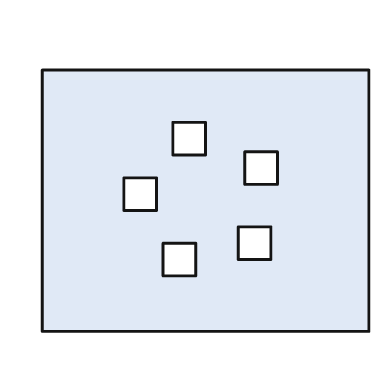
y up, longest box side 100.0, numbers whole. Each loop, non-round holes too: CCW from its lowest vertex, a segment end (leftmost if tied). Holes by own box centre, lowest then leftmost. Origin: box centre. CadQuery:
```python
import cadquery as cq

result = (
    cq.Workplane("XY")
    .moveTo(-50.0, -40.0)
    .lineTo(50.0, -40.0)
    .lineTo(50.0, 40.0)
    .lineTo(-50.0, 40.0)
    .close()
    .moveTo(-13.0, -23.0)
    .lineTo(-3.0, -23.0)
    .lineTo(-3.0, -13.0)
    .lineTo(-13.0, -13.0)
    .close()
    .moveTo(10.0, -18.0)
    .lineTo(20.0, -18.0)
    .lineTo(20.0, -8.0)
    .lineTo(10.0, -8.0)
    .close()
    .moveTo(-25.0, -3.0)
    .lineTo(-15.0, -3.0)
    .lineTo(-15.0, 7.0)
    .lineTo(-25.0, 7.0)
    .close()
    .moveTo(12.0, 5.0)
    .lineTo(22.0, 5.0)
    .lineTo(22.0, 15.0)
    .lineTo(12.0, 15.0)
    .close()
    .moveTo(-10.0, 14.0)
    .lineTo(0.0, 14.0)
    .lineTo(0.0, 24.0)
    .lineTo(-10.0, 24.0)
    .close()
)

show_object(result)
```